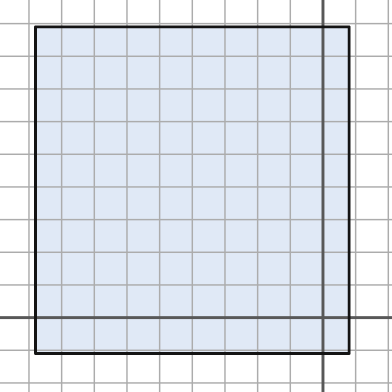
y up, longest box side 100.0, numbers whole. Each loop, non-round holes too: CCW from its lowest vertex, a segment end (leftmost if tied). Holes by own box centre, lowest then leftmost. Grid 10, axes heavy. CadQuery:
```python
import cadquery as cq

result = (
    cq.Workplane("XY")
    .moveTo(-88.0, -11.0)
    .lineTo(8.0, -11.0)
    .lineTo(8.0, 89.0)
    .lineTo(-88.0, 89.0)
    .close()
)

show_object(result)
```